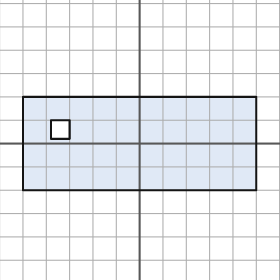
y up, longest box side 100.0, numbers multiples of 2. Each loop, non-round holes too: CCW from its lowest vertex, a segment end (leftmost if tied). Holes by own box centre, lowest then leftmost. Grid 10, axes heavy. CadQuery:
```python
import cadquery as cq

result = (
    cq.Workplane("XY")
    .moveTo(-50.0, -20.0)
    .lineTo(50.0, -20.0)
    .lineTo(50.0, 20.0)
    .lineTo(-50.0, 20.0)
    .close()
    .moveTo(-38.0, 2.0)
    .lineTo(-30.0, 2.0)
    .lineTo(-30.0, 10.0)
    .lineTo(-38.0, 10.0)
    .close()
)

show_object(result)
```